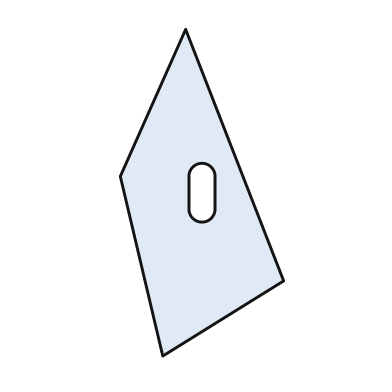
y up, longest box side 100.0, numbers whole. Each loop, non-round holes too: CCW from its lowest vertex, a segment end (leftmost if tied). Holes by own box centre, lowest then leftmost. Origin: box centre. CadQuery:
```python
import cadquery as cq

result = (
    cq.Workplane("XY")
    .moveTo(-12.0, -50.0)
    .lineTo(25.0, -27.0)
    .lineTo(-5.0, 50.0)
    .lineTo(-25.0, 5.0)
    .close()
    .moveTo(-4.0, -5.0)
    .threePointArc((0.0, -9.0), (4.0, -5.0))
    .lineTo(4.0, 5.0)
    .threePointArc((0.0, 9.0), (-4.0, 5.0))
    .close()
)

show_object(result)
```